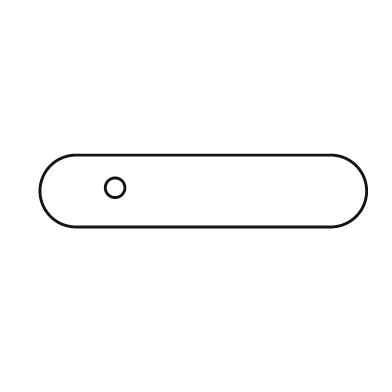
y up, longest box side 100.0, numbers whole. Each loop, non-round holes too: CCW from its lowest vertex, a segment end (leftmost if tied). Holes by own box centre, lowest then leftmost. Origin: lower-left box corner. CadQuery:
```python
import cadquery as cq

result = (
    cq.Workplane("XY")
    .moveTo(11.0, 0.0)
    .lineTo(89.0, 0.0)
    .threePointArc((100.0, 11.0), (89.0, 22.0))
    .lineTo(11.0, 22.0)
    .threePointArc((0.0, 11.0), (11.0, 0.0))
    .close()
    .moveTo(23.0, 12.0)
    .circle(3.0)
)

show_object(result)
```